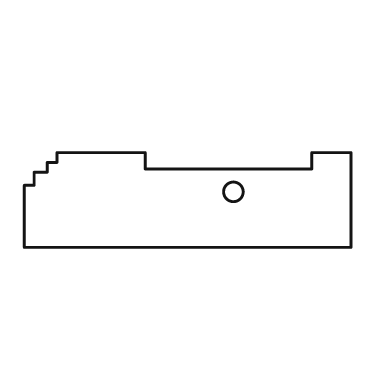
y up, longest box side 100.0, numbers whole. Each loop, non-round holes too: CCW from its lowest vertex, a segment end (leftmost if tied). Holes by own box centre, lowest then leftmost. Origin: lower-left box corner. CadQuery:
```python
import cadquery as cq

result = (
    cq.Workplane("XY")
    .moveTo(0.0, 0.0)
    .lineTo(100.0, 0.0)
    .lineTo(100.0, 29.0)
    .lineTo(88.0, 29.0)
    .lineTo(88.0, 24.0)
    .lineTo(37.0, 24.0)
    .lineTo(37.0, 29.0)
    .lineTo(10.0, 29.0)
    .lineTo(10.0, 26.0)
    .lineTo(7.0, 26.0)
    .lineTo(7.0, 23.0)
    .lineTo(3.0, 23.0)
    .lineTo(3.0, 19.0)
    .lineTo(0.0, 19.0)
    .close()
    .moveTo(64.0, 17.0)
    .circle(3.0)
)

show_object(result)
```